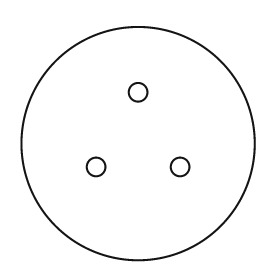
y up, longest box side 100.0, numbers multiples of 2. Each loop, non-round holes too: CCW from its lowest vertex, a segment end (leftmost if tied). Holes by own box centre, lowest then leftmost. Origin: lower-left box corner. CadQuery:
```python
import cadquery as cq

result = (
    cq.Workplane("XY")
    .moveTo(50.0, 50.0)
    .circle(50.0)
    .moveTo(32.0, 40.0)
    .circle(4.0)
    .moveTo(68.0, 40.0)
    .circle(4.0)
    .moveTo(50.0, 72.0)
    .circle(4.0)
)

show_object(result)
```